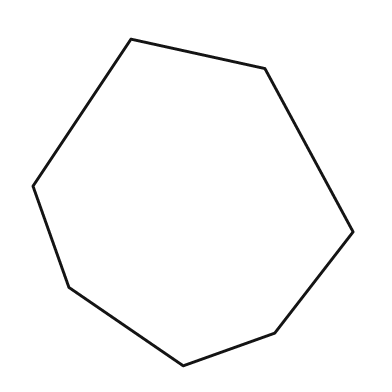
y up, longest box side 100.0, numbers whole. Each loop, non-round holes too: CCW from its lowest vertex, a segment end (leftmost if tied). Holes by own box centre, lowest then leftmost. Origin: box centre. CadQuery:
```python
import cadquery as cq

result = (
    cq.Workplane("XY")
    .moveTo(-3.0, -50.0)
    .lineTo(25.0, -40.0)
    .lineTo(49.0, -9.0)
    .lineTo(22.0, 41.0)
    .lineTo(-19.0, 50.0)
    .lineTo(-49.0, 5.0)
    .lineTo(-38.0, -26.0)
    .close()
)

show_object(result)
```